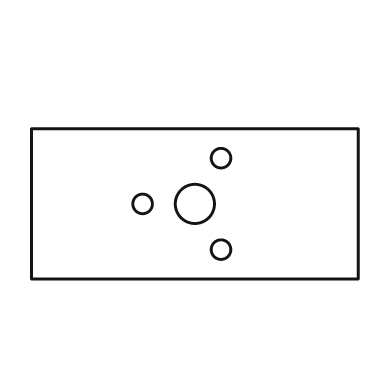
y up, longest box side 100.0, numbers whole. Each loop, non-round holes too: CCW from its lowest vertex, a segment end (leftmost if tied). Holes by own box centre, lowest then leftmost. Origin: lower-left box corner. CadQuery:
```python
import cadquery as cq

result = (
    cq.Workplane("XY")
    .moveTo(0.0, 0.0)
    .lineTo(100.0, 0.0)
    .lineTo(100.0, 46.0)
    .lineTo(0.0, 46.0)
    .close()
    .moveTo(58.0, 9.0)
    .circle(3.0)
    .moveTo(34.0, 23.0)
    .circle(3.0)
    .moveTo(50.0, 23.0)
    .circle(6.0)
    .moveTo(58.0, 37.0)
    .circle(3.0)
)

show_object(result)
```